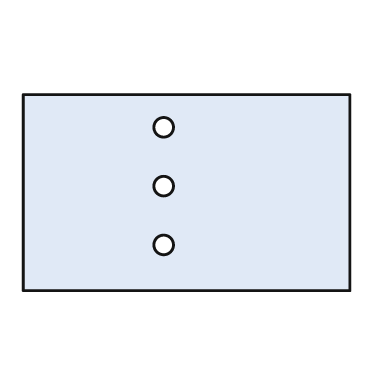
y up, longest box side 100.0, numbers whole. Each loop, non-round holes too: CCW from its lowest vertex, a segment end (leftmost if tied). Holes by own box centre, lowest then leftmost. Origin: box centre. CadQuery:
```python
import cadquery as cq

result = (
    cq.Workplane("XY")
    .moveTo(-50.0, -30.0)
    .lineTo(50.0, -30.0)
    .lineTo(50.0, 30.0)
    .lineTo(-50.0, 30.0)
    .close()
    .moveTo(-7.0, -16.0)
    .circle(3.0)
    .moveTo(-7.0, 2.0)
    .circle(3.0)
    .moveTo(-7.0, 20.0)
    .circle(3.0)
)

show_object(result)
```